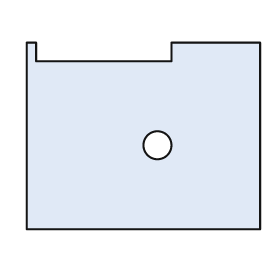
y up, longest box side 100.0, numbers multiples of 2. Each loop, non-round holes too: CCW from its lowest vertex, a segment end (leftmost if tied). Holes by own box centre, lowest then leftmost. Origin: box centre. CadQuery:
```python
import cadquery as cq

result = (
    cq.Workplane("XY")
    .moveTo(-50.0, -40.0)
    .lineTo(50.0, -40.0)
    .lineTo(50.0, 40.0)
    .lineTo(12.0, 40.0)
    .lineTo(12.0, 32.0)
    .lineTo(-46.0, 32.0)
    .lineTo(-46.0, 40.0)
    .lineTo(-50.0, 40.0)
    .close()
    .moveTo(6.0, -4.0)
    .circle(6.0)
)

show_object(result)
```